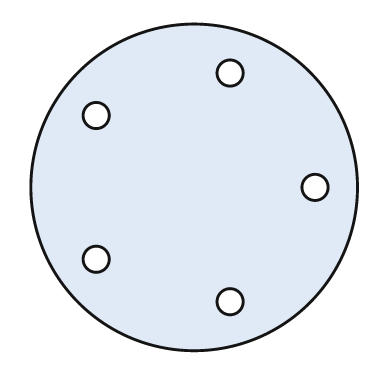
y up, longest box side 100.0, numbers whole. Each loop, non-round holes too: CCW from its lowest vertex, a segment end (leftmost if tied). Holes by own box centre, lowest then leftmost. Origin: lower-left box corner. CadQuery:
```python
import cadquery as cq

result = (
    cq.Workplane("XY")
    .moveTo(50.0, 50.0)
    .circle(50.0)
    .moveTo(61.0, 15.0)
    .circle(4.0)
    .moveTo(20.0, 28.0)
    .circle(4.0)
    .moveTo(87.0, 50.0)
    .circle(4.0)
    .moveTo(20.0, 72.0)
    .circle(4.0)
    .moveTo(61.0, 85.0)
    .circle(4.0)
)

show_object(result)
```